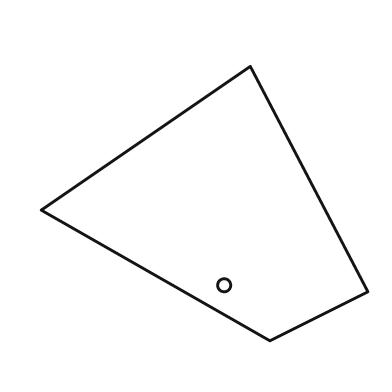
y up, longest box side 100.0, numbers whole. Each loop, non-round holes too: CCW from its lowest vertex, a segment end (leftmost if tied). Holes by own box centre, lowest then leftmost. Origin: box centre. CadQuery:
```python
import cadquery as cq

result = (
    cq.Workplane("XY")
    .moveTo(20.0, -42.0)
    .lineTo(50.0, -27.0)
    .lineTo(14.0, 42.0)
    .lineTo(-50.0, -2.0)
    .close()
    .moveTo(6.0, -25.0)
    .circle(2.0)
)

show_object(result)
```